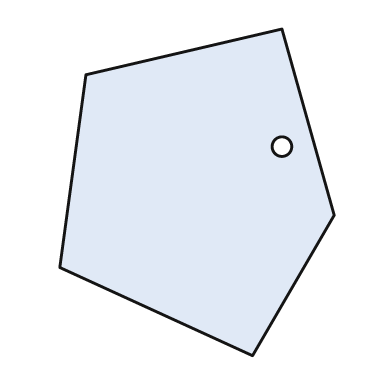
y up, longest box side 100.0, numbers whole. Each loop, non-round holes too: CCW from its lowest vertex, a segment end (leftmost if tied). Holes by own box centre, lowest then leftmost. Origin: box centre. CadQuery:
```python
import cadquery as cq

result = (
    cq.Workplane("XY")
    .moveTo(17.0, -50.0)
    .lineTo(42.0, -7.0)
    .lineTo(26.0, 50.0)
    .lineTo(-34.0, 36.0)
    .lineTo(-42.0, -23.0)
    .close()
    .moveTo(26.0, 14.0)
    .circle(3.0)
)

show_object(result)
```